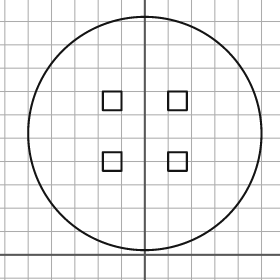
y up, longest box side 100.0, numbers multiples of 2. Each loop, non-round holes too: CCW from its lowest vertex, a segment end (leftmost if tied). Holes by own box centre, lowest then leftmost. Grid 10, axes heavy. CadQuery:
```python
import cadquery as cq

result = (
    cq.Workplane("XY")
    .moveTo(0.0, 52.0)
    .circle(50.0)
    .moveTo(-18.0, 36.0)
    .lineTo(-10.0, 36.0)
    .lineTo(-10.0, 44.0)
    .lineTo(-18.0, 44.0)
    .close()
    .moveTo(10.0, 36.0)
    .lineTo(18.0, 36.0)
    .lineTo(18.0, 44.0)
    .lineTo(10.0, 44.0)
    .close()
    .moveTo(-18.0, 62.0)
    .lineTo(-10.0, 62.0)
    .lineTo(-10.0, 70.0)
    .lineTo(-18.0, 70.0)
    .close()
    .moveTo(10.0, 62.0)
    .lineTo(18.0, 62.0)
    .lineTo(18.0, 70.0)
    .lineTo(10.0, 70.0)
    .close()
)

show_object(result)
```